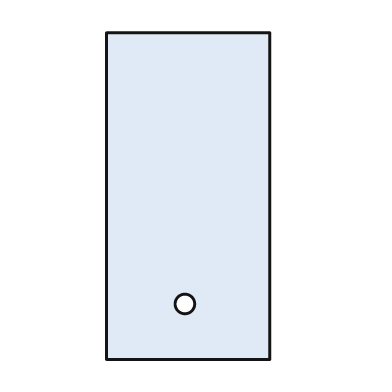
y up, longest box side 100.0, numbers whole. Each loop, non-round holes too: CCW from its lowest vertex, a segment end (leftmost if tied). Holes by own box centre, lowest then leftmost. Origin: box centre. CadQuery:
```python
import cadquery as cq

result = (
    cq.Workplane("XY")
    .moveTo(-25.0, -50.0)
    .lineTo(25.0, -50.0)
    .lineTo(25.0, 50.0)
    .lineTo(-25.0, 50.0)
    .close()
    .moveTo(-1.0, -33.0)
    .circle(3.0)
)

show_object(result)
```